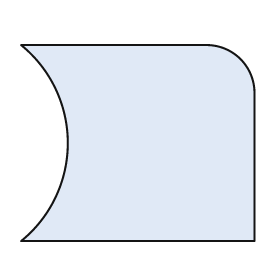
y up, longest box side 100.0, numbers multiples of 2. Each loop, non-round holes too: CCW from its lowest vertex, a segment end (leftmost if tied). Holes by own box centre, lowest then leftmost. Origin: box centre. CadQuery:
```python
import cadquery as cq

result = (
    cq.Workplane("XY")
    .moveTo(-50.0, -42.0)
    .lineTo(50.0, -42.0)
    .lineTo(50.0, 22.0)
    .threePointArc((44.0, 36.0), (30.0, 42.0))
    .lineTo(-50.0, 42.0)
    .threePointArc((-30.0, 0.0), (-50.0, -42.0))
    .close()
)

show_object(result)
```